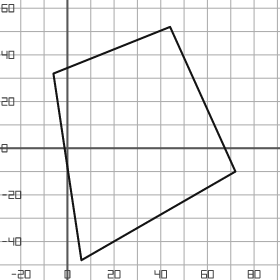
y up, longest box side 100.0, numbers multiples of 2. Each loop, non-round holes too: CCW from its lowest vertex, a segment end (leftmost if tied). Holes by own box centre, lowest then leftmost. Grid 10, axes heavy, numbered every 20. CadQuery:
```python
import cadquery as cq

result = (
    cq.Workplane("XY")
    .moveTo(6.0, -48.0)
    .lineTo(72.0, -10.0)
    .lineTo(44.0, 52.0)
    .lineTo(-6.0, 32.0)
    .close()
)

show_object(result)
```